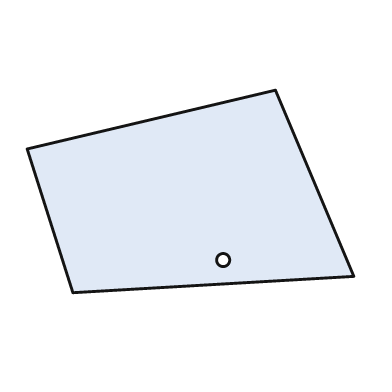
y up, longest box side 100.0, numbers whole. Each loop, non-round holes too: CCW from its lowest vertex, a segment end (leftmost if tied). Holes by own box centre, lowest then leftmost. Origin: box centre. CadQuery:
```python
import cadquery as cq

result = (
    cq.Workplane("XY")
    .moveTo(-36.0, -31.0)
    .lineTo(50.0, -26.0)
    .lineTo(26.0, 31.0)
    .lineTo(-50.0, 13.0)
    .close()
    .moveTo(10.0, -21.0)
    .circle(2.0)
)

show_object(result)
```